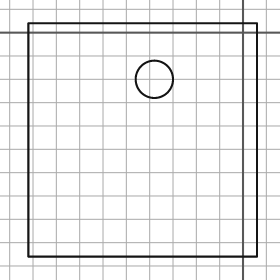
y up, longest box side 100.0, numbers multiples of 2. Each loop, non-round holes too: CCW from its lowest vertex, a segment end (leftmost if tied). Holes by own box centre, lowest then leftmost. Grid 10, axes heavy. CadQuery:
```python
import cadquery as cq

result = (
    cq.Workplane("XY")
    .moveTo(-92.0, -96.0)
    .lineTo(6.0, -96.0)
    .lineTo(6.0, 4.0)
    .lineTo(-92.0, 4.0)
    .close()
    .moveTo(-38.0, -20.0)
    .circle(8.0)
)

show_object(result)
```